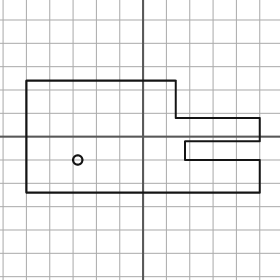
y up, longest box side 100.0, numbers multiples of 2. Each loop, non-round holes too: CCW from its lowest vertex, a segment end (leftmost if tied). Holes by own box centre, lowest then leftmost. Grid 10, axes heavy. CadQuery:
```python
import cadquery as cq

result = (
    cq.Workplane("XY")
    .moveTo(-50.0, -24.0)
    .lineTo(50.0, -24.0)
    .lineTo(50.0, -10.0)
    .lineTo(18.0, -10.0)
    .lineTo(18.0, -2.0)
    .lineTo(50.0, -2.0)
    .lineTo(50.0, 8.0)
    .lineTo(14.0, 8.0)
    .lineTo(14.0, 24.0)
    .lineTo(-50.0, 24.0)
    .close()
    .moveTo(-28.0, -10.0)
    .circle(2.0)
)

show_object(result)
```